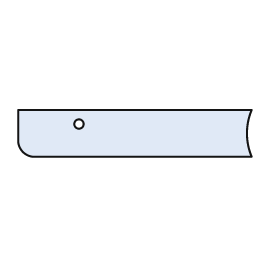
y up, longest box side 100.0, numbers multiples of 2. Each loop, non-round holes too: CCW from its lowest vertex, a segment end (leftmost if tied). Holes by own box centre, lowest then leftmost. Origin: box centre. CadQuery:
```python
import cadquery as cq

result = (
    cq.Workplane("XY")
    .moveTo(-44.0, -10.0)
    .lineTo(50.0, -10.0)
    .threePointArc((48.0, 0.0), (50.0, 10.0))
    .lineTo(-50.0, 10.0)
    .lineTo(-50.0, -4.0)
    .threePointArc((-48.0, -8.0), (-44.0, -10.0))
    .close()
    .moveTo(-24.0, 4.0)
    .circle(2.0)
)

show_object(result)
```